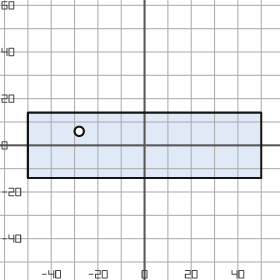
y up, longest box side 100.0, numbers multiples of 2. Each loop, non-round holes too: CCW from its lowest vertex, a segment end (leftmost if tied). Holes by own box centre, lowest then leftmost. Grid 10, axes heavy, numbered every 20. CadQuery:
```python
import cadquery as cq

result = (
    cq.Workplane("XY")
    .moveTo(-50.0, -14.0)
    .lineTo(50.0, -14.0)
    .lineTo(50.0, 14.0)
    .lineTo(-50.0, 14.0)
    .close()
    .moveTo(-28.0, 6.0)
    .circle(2.0)
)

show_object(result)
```